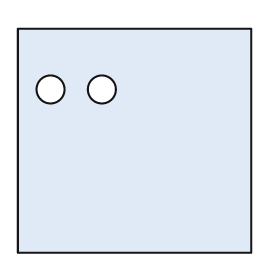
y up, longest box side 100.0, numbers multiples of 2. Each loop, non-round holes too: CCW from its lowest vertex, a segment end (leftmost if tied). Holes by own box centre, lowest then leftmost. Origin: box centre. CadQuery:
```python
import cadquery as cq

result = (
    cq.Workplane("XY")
    .moveTo(-50.0, -48.0)
    .lineTo(50.0, -48.0)
    .lineTo(50.0, 48.0)
    .lineTo(-50.0, 48.0)
    .close()
    .moveTo(-36.0, 22.0)
    .circle(6.0)
    .moveTo(-14.0, 22.0)
    .circle(6.0)
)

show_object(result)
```